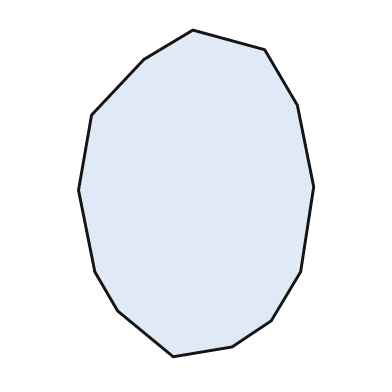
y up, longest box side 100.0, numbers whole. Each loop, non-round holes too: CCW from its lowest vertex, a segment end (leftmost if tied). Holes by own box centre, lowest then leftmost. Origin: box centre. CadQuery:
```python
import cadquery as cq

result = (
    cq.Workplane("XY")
    .moveTo(-7.0, -50.0)
    .lineTo(11.0, -47.0)
    .lineTo(23.0, -39.0)
    .lineTo(32.0, -24.0)
    .lineTo(36.0, 2.0)
    .lineTo(31.0, 27.0)
    .lineTo(21.0, 44.0)
    .lineTo(-1.0, 50.0)
    .lineTo(-16.0, 41.0)
    .lineTo(-32.0, 24.0)
    .lineTo(-36.0, 1.0)
    .lineTo(-31.0, -24.0)
    .lineTo(-24.0, -36.0)
    .close()
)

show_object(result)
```